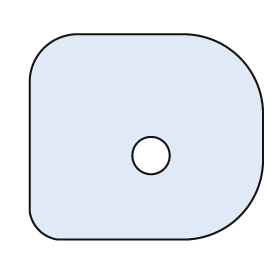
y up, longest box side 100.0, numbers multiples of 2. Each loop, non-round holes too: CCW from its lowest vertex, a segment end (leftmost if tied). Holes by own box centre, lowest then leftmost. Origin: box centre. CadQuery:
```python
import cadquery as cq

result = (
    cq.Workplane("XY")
    .moveTo(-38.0, -44.0)
    .lineTo(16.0, -44.0)
    .threePointArc((40.0, -34.0), (50.0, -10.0))
    .lineTo(50.0, 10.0)
    .threePointArc((40.0, 34.0), (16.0, 44.0))
    .lineTo(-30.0, 44.0)
    .threePointArc((-44.0, 38.0), (-50.0, 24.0))
    .lineTo(-50.0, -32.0)
    .threePointArc((-46.0, -40.0), (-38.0, -44.0))
    .close()
    .moveTo(2.0, -8.0)
    .circle(8.0)
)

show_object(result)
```